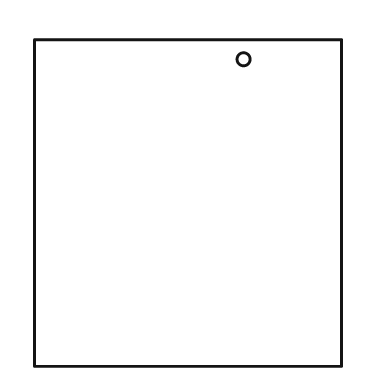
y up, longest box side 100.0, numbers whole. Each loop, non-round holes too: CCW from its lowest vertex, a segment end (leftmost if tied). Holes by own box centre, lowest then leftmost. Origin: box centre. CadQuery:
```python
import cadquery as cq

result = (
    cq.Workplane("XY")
    .moveTo(-47.0, -50.0)
    .lineTo(47.0, -50.0)
    .lineTo(47.0, 50.0)
    .lineTo(-47.0, 50.0)
    .close()
    .moveTo(17.0, 44.0)
    .circle(2.0)
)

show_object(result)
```